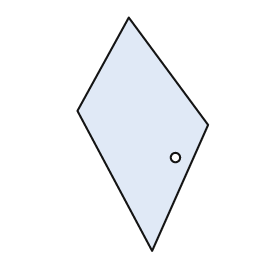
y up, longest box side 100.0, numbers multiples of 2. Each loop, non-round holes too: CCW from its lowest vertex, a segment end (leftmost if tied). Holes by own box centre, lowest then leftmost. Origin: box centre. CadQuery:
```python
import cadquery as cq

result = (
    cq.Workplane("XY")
    .moveTo(4.0, -50.0)
    .lineTo(28.0, 4.0)
    .lineTo(-6.0, 50.0)
    .lineTo(-28.0, 10.0)
    .close()
    .moveTo(14.0, -10.0)
    .circle(2.0)
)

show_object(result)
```